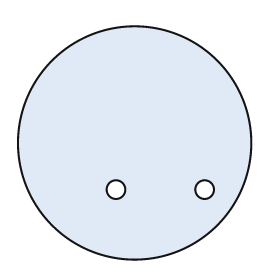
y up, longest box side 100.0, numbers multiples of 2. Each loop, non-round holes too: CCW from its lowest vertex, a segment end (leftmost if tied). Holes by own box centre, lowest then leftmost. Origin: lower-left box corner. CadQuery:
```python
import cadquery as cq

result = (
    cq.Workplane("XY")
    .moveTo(50.0, 50.0)
    .circle(50.0)
    .moveTo(42.0, 30.0)
    .circle(4.0)
    .moveTo(80.0, 30.0)
    .circle(4.0)
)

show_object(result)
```